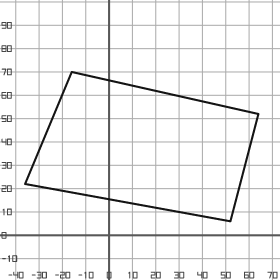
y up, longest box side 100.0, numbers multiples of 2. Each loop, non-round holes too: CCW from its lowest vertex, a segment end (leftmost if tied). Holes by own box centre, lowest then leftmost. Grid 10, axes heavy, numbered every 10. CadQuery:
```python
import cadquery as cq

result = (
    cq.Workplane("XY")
    .moveTo(52.0, 6.0)
    .lineTo(64.0, 52.0)
    .lineTo(-16.0, 70.0)
    .lineTo(-36.0, 22.0)
    .close()
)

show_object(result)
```